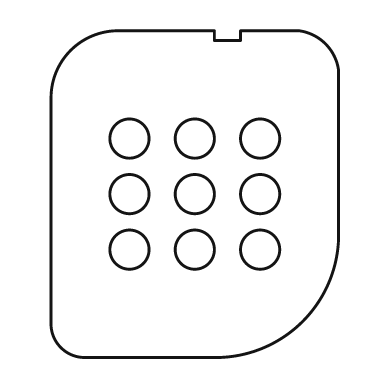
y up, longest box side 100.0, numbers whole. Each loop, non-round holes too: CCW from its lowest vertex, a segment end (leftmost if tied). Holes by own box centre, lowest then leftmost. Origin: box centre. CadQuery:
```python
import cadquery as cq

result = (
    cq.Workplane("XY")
    .moveTo(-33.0, -50.0)
    .lineTo(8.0, -50.0)
    .threePointArc((33.0, -39.0), (44.0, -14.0))
    .lineTo(44.0, 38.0)
    .threePointArc((40.0, 46.0), (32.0, 50.0))
    .lineTo(14.0, 50.0)
    .lineTo(14.0, 47.0)
    .lineTo(6.0, 47.0)
    .lineTo(6.0, 50.0)
    .lineTo(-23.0, 50.0)
    .threePointArc((-38.0, 44.0), (-44.0, 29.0))
    .lineTo(-44.0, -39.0)
    .threePointArc((-41.0, -47.0), (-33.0, -50.0))
    .close()
    .moveTo(-20.0, -17.0)
    .circle(6.0)
    .moveTo(0.0, -17.0)
    .circle(6.0)
    .moveTo(20.0, -17.0)
    .circle(6.0)
    .moveTo(-20.0, 0.0)
    .circle(6.0)
    .moveTo(0.0, 0.0)
    .circle(6.0)
    .moveTo(20.0, 0.0)
    .circle(6.0)
    .moveTo(-20.0, 17.0)
    .circle(6.0)
    .moveTo(0.0, 17.0)
    .circle(6.0)
    .moveTo(20.0, 17.0)
    .circle(6.0)
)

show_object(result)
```